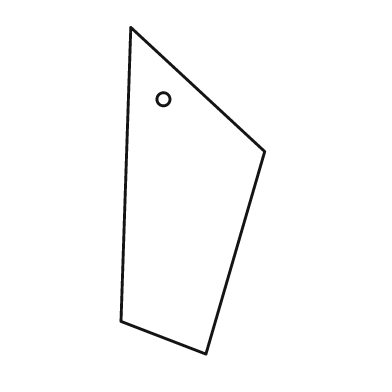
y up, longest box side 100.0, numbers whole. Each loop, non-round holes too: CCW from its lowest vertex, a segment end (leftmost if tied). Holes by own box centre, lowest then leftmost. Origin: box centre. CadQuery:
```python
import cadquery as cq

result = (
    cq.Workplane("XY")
    .moveTo(4.0, -50.0)
    .lineTo(22.0, 12.0)
    .lineTo(-19.0, 50.0)
    .lineTo(-22.0, -40.0)
    .close()
    .moveTo(-9.0, 28.0)
    .circle(2.0)
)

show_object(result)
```